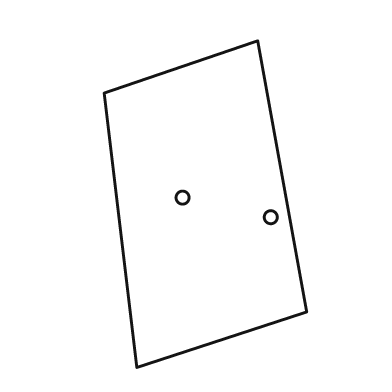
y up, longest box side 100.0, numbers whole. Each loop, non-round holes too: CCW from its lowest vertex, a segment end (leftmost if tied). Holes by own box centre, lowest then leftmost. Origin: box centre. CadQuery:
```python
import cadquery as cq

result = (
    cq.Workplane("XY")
    .moveTo(-21.0, -50.0)
    .lineTo(31.0, -33.0)
    .lineTo(16.0, 50.0)
    .lineTo(-31.0, 34.0)
    .close()
    .moveTo(20.0, -4.0)
    .circle(2.0)
    .moveTo(-7.0, 2.0)
    .circle(2.0)
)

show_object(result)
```